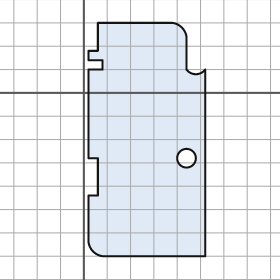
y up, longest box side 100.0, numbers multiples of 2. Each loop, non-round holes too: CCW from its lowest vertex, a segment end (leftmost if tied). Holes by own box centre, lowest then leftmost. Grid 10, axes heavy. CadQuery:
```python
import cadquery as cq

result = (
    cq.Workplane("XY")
    .moveTo(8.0, -70.0)
    .lineTo(52.0, -70.0)
    .lineTo(52.0, 10.0)
    .threePointArc((48.0, 8.0), (44.0, 10.0))
    .lineTo(44.0, 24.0)
    .threePointArc((42.0, 28.0), (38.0, 30.0))
    .lineTo(6.0, 30.0)
    .lineTo(6.0, 18.0)
    .lineTo(2.0, 18.0)
    .lineTo(2.0, 14.0)
    .lineTo(8.0, 14.0)
    .lineTo(8.0, 10.0)
    .lineTo(2.0, 10.0)
    .lineTo(2.0, -28.0)
    .lineTo(6.0, -28.0)
    .lineTo(6.0, -44.0)
    .lineTo(2.0, -44.0)
    .lineTo(2.0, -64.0)
    .threePointArc((4.0, -68.0), (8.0, -70.0))
    .close()
    .moveTo(44.0, -28.0)
    .circle(4.0)
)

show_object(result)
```